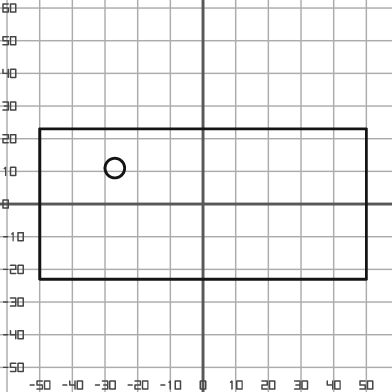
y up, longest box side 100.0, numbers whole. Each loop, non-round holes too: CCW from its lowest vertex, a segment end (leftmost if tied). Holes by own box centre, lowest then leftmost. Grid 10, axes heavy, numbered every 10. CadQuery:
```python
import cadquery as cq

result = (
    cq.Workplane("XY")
    .moveTo(-50.0, -23.0)
    .lineTo(50.0, -23.0)
    .lineTo(50.0, 23.0)
    .lineTo(-50.0, 23.0)
    .close()
    .moveTo(-27.0, 11.0)
    .circle(3.0)
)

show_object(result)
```